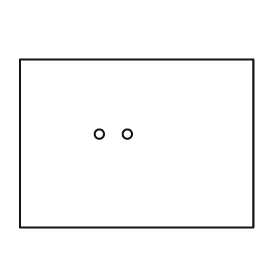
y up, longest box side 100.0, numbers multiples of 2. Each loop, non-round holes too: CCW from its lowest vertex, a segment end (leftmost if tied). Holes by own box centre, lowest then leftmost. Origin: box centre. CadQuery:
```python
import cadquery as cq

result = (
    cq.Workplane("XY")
    .moveTo(-50.0, -36.0)
    .lineTo(50.0, -36.0)
    .lineTo(50.0, 36.0)
    .lineTo(-50.0, 36.0)
    .close()
    .moveTo(-16.0, 4.0)
    .circle(2.0)
    .moveTo(-4.0, 4.0)
    .circle(2.0)
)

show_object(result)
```